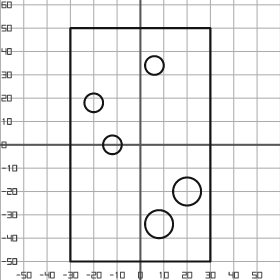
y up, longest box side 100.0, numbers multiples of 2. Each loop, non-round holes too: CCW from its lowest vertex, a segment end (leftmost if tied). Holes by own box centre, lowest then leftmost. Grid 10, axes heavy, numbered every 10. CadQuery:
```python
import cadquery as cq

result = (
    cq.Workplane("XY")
    .moveTo(-30.0, -50.0)
    .lineTo(30.0, -50.0)
    .lineTo(30.0, 50.0)
    .lineTo(-30.0, 50.0)
    .close()
    .moveTo(8.0, -34.0)
    .circle(6.0)
    .moveTo(20.0, -20.0)
    .circle(6.0)
    .moveTo(-12.0, 0.0)
    .circle(4.0)
    .moveTo(-20.0, 18.0)
    .circle(4.0)
    .moveTo(6.0, 34.0)
    .circle(4.0)
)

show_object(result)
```